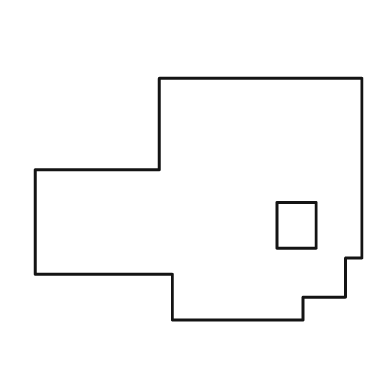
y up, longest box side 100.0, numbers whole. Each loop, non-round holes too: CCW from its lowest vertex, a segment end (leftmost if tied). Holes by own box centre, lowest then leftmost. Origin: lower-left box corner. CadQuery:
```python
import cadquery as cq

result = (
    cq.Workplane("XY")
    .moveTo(42.0, 0.0)
    .lineTo(82.0, 0.0)
    .lineTo(82.0, 7.0)
    .lineTo(95.0, 7.0)
    .lineTo(95.0, 19.0)
    .lineTo(100.0, 19.0)
    .lineTo(100.0, 74.0)
    .lineTo(38.0, 74.0)
    .lineTo(38.0, 46.0)
    .lineTo(0.0, 46.0)
    .lineTo(0.0, 14.0)
    .lineTo(42.0, 14.0)
    .close()
    .moveTo(74.0, 22.0)
    .lineTo(86.0, 22.0)
    .lineTo(86.0, 36.0)
    .lineTo(74.0, 36.0)
    .close()
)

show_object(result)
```